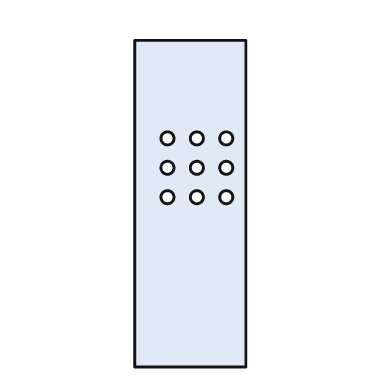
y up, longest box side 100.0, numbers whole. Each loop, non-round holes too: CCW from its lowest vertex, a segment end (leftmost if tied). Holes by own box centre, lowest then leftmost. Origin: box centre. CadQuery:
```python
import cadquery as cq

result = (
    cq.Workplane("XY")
    .moveTo(-17.0, -50.0)
    .lineTo(17.0, -50.0)
    .lineTo(17.0, 50.0)
    .lineTo(-17.0, 50.0)
    .close()
    .moveTo(-7.0, 2.0)
    .circle(2.0)
    .moveTo(2.0, 2.0)
    .circle(2.0)
    .moveTo(11.0, 2.0)
    .circle(2.0)
    .moveTo(-7.0, 11.0)
    .circle(2.0)
    .moveTo(2.0, 11.0)
    .circle(2.0)
    .moveTo(11.0, 11.0)
    .circle(2.0)
    .moveTo(-7.0, 20.0)
    .circle(2.0)
    .moveTo(2.0, 20.0)
    .circle(2.0)
    .moveTo(11.0, 20.0)
    .circle(2.0)
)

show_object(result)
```